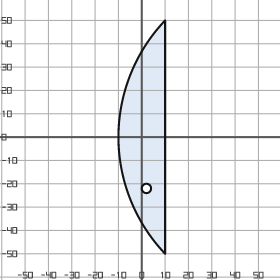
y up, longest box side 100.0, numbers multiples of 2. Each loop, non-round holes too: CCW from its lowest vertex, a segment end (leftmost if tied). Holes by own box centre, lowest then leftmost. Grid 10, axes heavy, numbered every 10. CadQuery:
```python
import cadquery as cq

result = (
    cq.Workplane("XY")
    .moveTo(10.0, -50.0)
    .lineTo(10.0, 50.0)
    .threePointArc((-10.0, 0.0), (10.0, -50.0))
    .close()
    .moveTo(2.0, -22.0)
    .circle(2.0)
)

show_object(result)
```